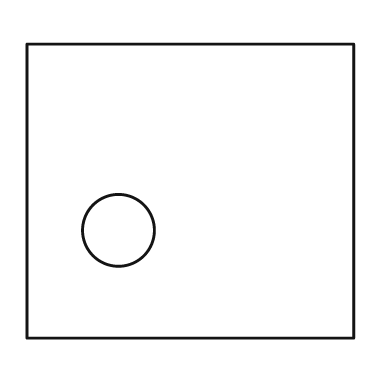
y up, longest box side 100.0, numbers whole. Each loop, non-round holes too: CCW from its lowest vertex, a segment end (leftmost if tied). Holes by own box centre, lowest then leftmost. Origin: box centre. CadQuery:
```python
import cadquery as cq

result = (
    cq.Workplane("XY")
    .moveTo(-50.0, -45.0)
    .lineTo(50.0, -45.0)
    .lineTo(50.0, 45.0)
    .lineTo(-50.0, 45.0)
    .close()
    .moveTo(-22.0, -12.0)
    .circle(11.0)
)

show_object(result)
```